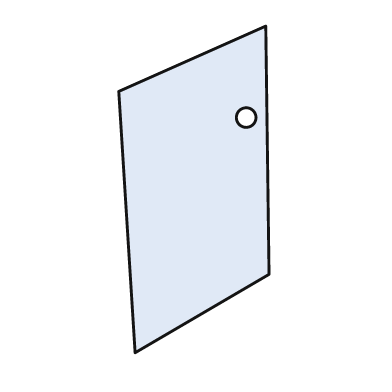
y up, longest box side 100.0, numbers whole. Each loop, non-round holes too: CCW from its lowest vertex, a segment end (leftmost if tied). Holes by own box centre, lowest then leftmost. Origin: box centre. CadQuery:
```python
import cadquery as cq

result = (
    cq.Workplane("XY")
    .moveTo(-18.0, -50.0)
    .lineTo(23.0, -26.0)
    .lineTo(22.0, 50.0)
    .lineTo(-23.0, 30.0)
    .close()
    .moveTo(16.0, 22.0)
    .circle(3.0)
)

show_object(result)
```